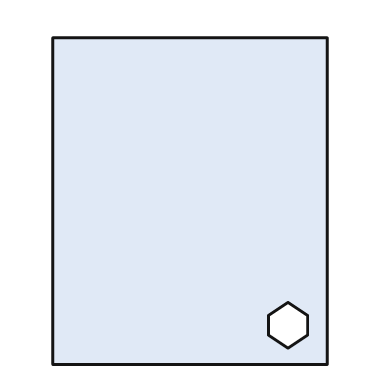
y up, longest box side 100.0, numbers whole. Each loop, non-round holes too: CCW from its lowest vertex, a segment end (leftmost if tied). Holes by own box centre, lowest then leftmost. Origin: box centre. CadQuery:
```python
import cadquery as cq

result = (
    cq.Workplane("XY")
    .moveTo(-42.0, -50.0)
    .lineTo(42.0, -50.0)
    .lineTo(42.0, 50.0)
    .lineTo(-42.0, 50.0)
    .close()
    .moveTo(30.0, -45.0)
    .lineTo(36.0, -41.0)
    .lineTo(36.0, -35.0)
    .lineTo(30.0, -31.0)
    .lineTo(24.0, -35.0)
    .lineTo(24.0, -41.0)
    .close()
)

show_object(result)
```